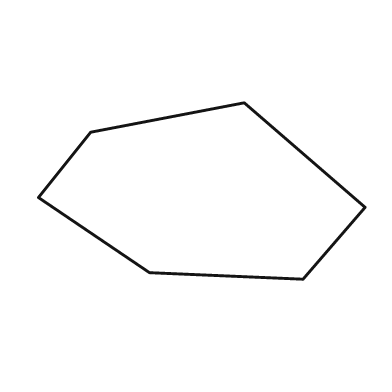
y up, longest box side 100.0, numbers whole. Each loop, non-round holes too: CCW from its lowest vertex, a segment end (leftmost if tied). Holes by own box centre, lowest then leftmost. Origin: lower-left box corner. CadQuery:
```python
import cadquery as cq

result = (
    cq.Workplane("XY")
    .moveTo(81.0, 0.0)
    .lineTo(100.0, 22.0)
    .lineTo(63.0, 54.0)
    .lineTo(16.0, 45.0)
    .lineTo(0.0, 25.0)
    .lineTo(34.0, 2.0)
    .close()
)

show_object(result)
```